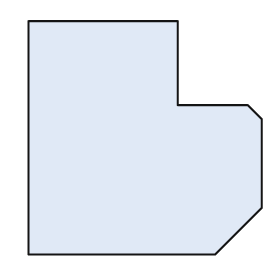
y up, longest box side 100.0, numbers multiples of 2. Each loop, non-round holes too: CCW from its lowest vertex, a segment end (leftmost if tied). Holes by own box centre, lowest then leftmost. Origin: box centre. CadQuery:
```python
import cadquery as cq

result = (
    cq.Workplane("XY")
    .moveTo(-50.0, -50.0)
    .lineTo(30.0, -50.0)
    .lineTo(50.0, -30.0)
    .lineTo(50.0, 8.0)
    .lineTo(44.0, 14.0)
    .lineTo(14.0, 14.0)
    .lineTo(14.0, 50.0)
    .lineTo(-50.0, 50.0)
    .close()
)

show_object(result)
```